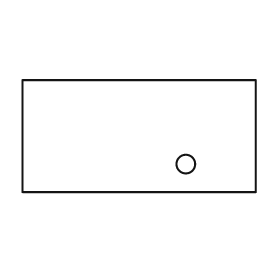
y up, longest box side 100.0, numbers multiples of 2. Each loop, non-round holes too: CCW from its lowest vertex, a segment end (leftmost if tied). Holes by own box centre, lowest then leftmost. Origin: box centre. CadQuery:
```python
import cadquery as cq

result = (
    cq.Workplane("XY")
    .moveTo(-50.0, -24.0)
    .lineTo(50.0, -24.0)
    .lineTo(50.0, 24.0)
    .lineTo(-50.0, 24.0)
    .close()
    .moveTo(20.0, -12.0)
    .circle(4.0)
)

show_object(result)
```